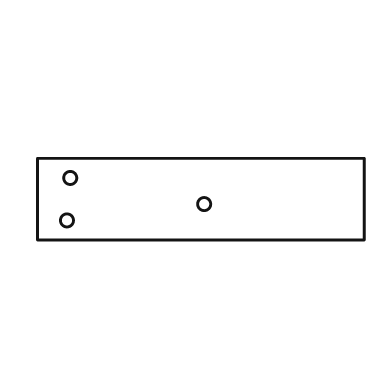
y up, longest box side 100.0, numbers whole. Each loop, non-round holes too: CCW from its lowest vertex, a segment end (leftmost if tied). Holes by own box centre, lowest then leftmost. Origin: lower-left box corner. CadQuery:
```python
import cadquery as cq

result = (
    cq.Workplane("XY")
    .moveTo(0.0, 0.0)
    .lineTo(100.0, 0.0)
    .lineTo(100.0, 25.0)
    .lineTo(0.0, 25.0)
    .close()
    .moveTo(9.0, 6.0)
    .circle(2.0)
    .moveTo(51.0, 11.0)
    .circle(2.0)
    .moveTo(10.0, 19.0)
    .circle(2.0)
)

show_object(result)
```